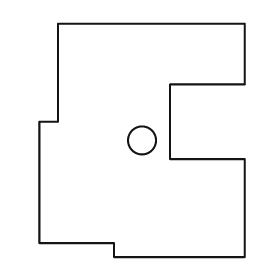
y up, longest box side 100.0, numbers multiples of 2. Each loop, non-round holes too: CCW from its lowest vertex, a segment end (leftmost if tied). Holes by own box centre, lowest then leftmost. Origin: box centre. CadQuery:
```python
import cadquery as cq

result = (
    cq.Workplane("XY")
    .moveTo(-12.0, -50.0)
    .lineTo(44.0, -50.0)
    .lineTo(44.0, -8.0)
    .lineTo(12.0, -8.0)
    .lineTo(12.0, 24.0)
    .lineTo(44.0, 24.0)
    .lineTo(44.0, 50.0)
    .lineTo(-36.0, 50.0)
    .lineTo(-36.0, 8.0)
    .lineTo(-44.0, 8.0)
    .lineTo(-44.0, -44.0)
    .lineTo(-12.0, -44.0)
    .close()
    .moveTo(0.0, 0.0)
    .circle(6.0)
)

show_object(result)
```